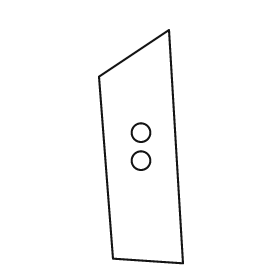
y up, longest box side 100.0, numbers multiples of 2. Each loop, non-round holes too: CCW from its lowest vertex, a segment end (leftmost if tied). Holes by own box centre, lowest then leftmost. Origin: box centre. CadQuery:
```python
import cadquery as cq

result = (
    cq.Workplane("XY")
    .moveTo(18.0, -50.0)
    .lineTo(12.0, 50.0)
    .lineTo(-18.0, 30.0)
    .lineTo(-12.0, -48.0)
    .close()
    .moveTo(0.0, -6.0)
    .circle(4.0)
    .moveTo(0.0, 6.0)
    .circle(4.0)
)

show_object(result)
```